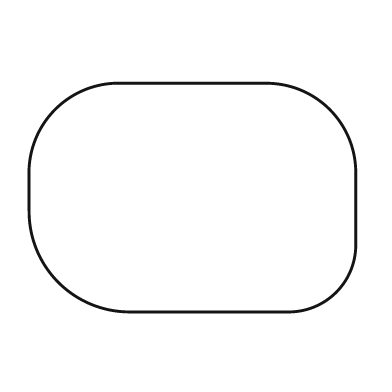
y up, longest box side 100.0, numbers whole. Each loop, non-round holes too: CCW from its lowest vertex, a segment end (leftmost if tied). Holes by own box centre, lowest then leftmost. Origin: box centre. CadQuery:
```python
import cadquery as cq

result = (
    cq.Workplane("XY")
    .moveTo(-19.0, -35.0)
    .lineTo(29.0, -35.0)
    .threePointArc((44.0, -29.0), (50.0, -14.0))
    .lineTo(50.0, 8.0)
    .threePointArc((42.0, 27.0), (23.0, 35.0))
    .lineTo(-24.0, 35.0)
    .threePointArc((-42.0, 27.0), (-50.0, 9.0))
    .lineTo(-50.0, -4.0)
    .threePointArc((-41.0, -26.0), (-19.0, -35.0))
    .close()
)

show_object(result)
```